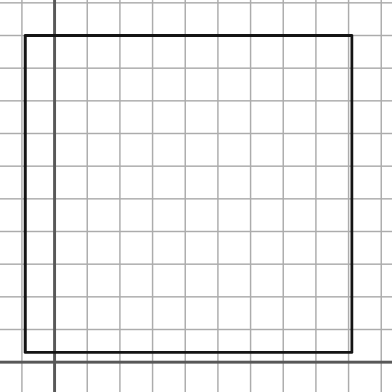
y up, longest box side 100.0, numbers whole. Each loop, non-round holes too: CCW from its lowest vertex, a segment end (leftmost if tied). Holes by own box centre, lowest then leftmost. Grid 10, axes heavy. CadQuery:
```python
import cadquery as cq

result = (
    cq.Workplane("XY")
    .moveTo(-9.0, 3.0)
    .lineTo(91.0, 3.0)
    .lineTo(91.0, 100.0)
    .lineTo(-9.0, 100.0)
    .close()
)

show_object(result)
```